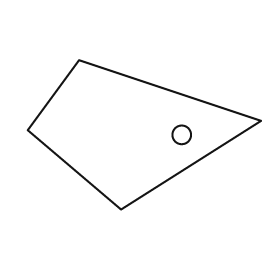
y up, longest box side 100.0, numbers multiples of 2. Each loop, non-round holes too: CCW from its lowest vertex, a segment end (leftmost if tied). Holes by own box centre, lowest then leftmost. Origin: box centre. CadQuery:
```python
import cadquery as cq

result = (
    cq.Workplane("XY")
    .moveTo(-10.0, -32.0)
    .lineTo(50.0, 6.0)
    .lineTo(-28.0, 32.0)
    .lineTo(-50.0, 2.0)
    .close()
    .moveTo(16.0, 0.0)
    .circle(4.0)
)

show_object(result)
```